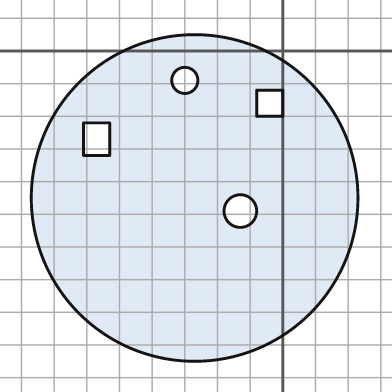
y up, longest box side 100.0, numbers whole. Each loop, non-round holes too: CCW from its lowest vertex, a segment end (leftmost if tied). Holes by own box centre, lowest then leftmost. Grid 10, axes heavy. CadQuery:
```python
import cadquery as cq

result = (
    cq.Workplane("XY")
    .moveTo(-27.0, -45.0)
    .circle(50.0)
    .moveTo(-13.0, -49.0)
    .circle(5.0)
    .moveTo(-61.0, -32.0)
    .lineTo(-53.0, -32.0)
    .lineTo(-53.0, -22.0)
    .lineTo(-61.0, -22.0)
    .close()
    .moveTo(-8.0, -20.0)
    .lineTo(0.0, -20.0)
    .lineTo(0.0, -12.0)
    .lineTo(-8.0, -12.0)
    .close()
    .moveTo(-30.0, -9.0)
    .circle(4.0)
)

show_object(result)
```